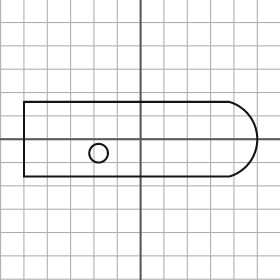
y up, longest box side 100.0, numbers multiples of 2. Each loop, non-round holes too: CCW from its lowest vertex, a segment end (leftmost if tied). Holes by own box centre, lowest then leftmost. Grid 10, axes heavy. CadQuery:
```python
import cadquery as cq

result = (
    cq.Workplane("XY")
    .moveTo(-50.0, -16.0)
    .lineTo(38.0, -16.0)
    .threePointArc((50.0, 0.0), (38.0, 16.0))
    .lineTo(-50.0, 16.0)
    .close()
    .moveTo(-18.0, -6.0)
    .circle(4.0)
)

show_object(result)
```